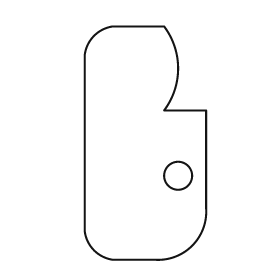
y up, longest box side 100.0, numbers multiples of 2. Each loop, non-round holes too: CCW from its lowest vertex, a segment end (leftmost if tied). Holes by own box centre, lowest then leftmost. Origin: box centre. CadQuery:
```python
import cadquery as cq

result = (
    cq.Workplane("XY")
    .moveTo(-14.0, -50.0)
    .lineTo(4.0, -50.0)
    .threePointArc((20.0, -44.0), (26.0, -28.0))
    .lineTo(26.0, 14.0)
    .lineTo(8.0, 14.0)
    .threePointArc((14.0, 32.0), (8.0, 50.0))
    .lineTo(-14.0, 50.0)
    .threePointArc((-22.0, 46.0), (-26.0, 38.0))
    .lineTo(-26.0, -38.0)
    .threePointArc((-22.0, -46.0), (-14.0, -50.0))
    .close()
    .moveTo(14.0, -14.0)
    .circle(6.0)
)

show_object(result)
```